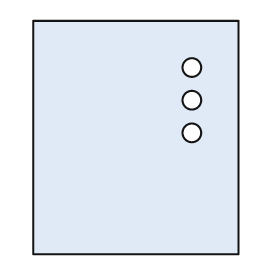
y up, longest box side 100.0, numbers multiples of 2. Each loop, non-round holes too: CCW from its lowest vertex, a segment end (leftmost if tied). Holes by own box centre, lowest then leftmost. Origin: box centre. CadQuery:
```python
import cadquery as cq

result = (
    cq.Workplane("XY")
    .moveTo(-44.0, -50.0)
    .lineTo(44.0, -50.0)
    .lineTo(44.0, 50.0)
    .lineTo(-44.0, 50.0)
    .close()
    .moveTo(24.0, 2.0)
    .circle(4.0)
    .moveTo(24.0, 16.0)
    .circle(4.0)
    .moveTo(24.0, 30.0)
    .circle(4.0)
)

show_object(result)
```